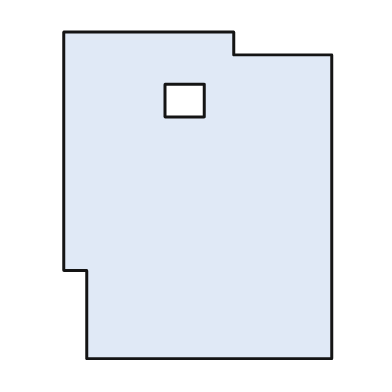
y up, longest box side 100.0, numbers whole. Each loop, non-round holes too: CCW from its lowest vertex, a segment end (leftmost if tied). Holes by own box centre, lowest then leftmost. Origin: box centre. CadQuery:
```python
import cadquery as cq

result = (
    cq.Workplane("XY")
    .moveTo(-34.0, -50.0)
    .lineTo(41.0, -50.0)
    .lineTo(41.0, 43.0)
    .lineTo(11.0, 43.0)
    .lineTo(11.0, 50.0)
    .lineTo(-41.0, 50.0)
    .lineTo(-41.0, -23.0)
    .lineTo(-34.0, -23.0)
    .close()
    .moveTo(-10.0, 24.0)
    .lineTo(2.0, 24.0)
    .lineTo(2.0, 34.0)
    .lineTo(-10.0, 34.0)
    .close()
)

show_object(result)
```